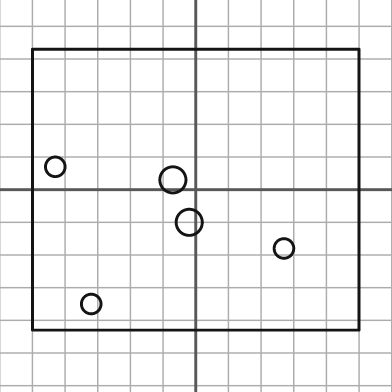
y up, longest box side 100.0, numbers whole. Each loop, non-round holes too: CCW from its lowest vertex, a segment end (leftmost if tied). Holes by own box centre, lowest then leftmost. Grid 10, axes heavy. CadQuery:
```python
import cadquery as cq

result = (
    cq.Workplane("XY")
    .moveTo(-50.0, -43.0)
    .lineTo(50.0, -43.0)
    .lineTo(50.0, 43.0)
    .lineTo(-50.0, 43.0)
    .close()
    .moveTo(-32.0, -35.0)
    .circle(3.0)
    .moveTo(27.0, -18.0)
    .circle(3.0)
    .moveTo(-2.0, -10.0)
    .circle(4.0)
    .moveTo(-7.0, 3.0)
    .circle(4.0)
    .moveTo(-43.0, 7.0)
    .circle(3.0)
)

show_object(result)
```